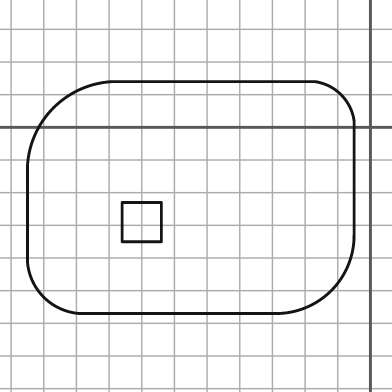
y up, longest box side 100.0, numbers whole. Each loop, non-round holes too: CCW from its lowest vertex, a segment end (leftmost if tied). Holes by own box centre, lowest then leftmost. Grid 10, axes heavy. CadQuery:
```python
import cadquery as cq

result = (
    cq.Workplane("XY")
    .moveTo(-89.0, -57.0)
    .lineTo(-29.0, -57.0)
    .threePointArc((-12.0, -50.0), (-5.0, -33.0))
    .lineTo(-5.0, 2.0)
    .threePointArc((-9.0, 10.0), (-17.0, 14.0))
    .lineTo(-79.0, 14.0)
    .threePointArc((-97.0, 6.0), (-105.0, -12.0))
    .lineTo(-105.0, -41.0)
    .threePointArc((-100.0, -52.0), (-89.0, -57.0))
    .close()
    .moveTo(-76.0, -35.0)
    .lineTo(-64.0, -35.0)
    .lineTo(-64.0, -23.0)
    .lineTo(-76.0, -23.0)
    .close()
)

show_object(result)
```